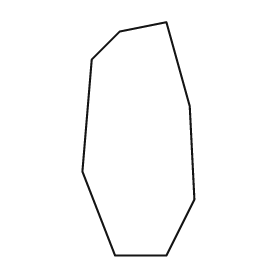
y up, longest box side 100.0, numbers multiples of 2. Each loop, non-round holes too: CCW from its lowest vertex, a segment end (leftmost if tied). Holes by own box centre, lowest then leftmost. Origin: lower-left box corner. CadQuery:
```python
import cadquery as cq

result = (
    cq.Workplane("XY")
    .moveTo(14.0, 0.0)
    .lineTo(36.0, 0.0)
    .lineTo(48.0, 24.0)
    .lineTo(46.0, 64.0)
    .lineTo(36.0, 100.0)
    .lineTo(16.0, 96.0)
    .lineTo(4.0, 84.0)
    .lineTo(0.0, 36.0)
    .close()
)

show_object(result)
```